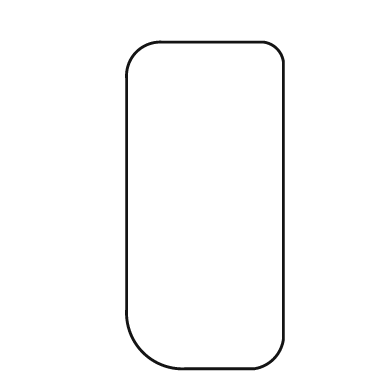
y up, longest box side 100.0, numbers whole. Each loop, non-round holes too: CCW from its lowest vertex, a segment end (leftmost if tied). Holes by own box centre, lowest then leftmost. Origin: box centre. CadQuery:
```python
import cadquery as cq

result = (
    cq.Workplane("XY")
    .moveTo(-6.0, -50.0)
    .lineTo(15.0, -50.0)
    .threePointArc((21.0, -47.0), (24.0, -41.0))
    .lineTo(24.0, 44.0)
    .threePointArc((22.0, 48.0), (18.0, 50.0))
    .lineTo(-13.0, 50.0)
    .threePointArc((-21.0, 47.0), (-24.0, 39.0))
    .lineTo(-24.0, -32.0)
    .threePointArc((-19.0, -45.0), (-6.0, -50.0))
    .close()
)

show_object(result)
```